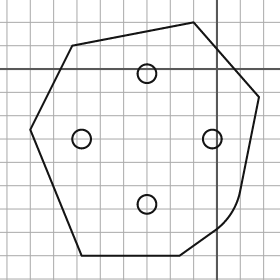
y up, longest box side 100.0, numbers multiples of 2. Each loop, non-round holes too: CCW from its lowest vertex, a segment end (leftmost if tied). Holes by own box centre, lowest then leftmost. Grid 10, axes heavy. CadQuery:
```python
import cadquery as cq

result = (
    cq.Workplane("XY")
    .moveTo(-58.0, -80.0)
    .lineTo(-16.0, -80.0)
    .lineTo(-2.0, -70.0)
    .threePointArc((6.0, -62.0), (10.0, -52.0))
    .lineTo(18.0, -12.0)
    .lineTo(-10.0, 20.0)
    .lineTo(-62.0, 10.0)
    .lineTo(-80.0, -26.0)
    .close()
    .moveTo(-30.0, -58.0)
    .circle(4.0)
    .moveTo(-58.0, -30.0)
    .circle(4.0)
    .moveTo(-2.0, -30.0)
    .circle(4.0)
    .moveTo(-30.0, -2.0)
    .circle(4.0)
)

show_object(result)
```